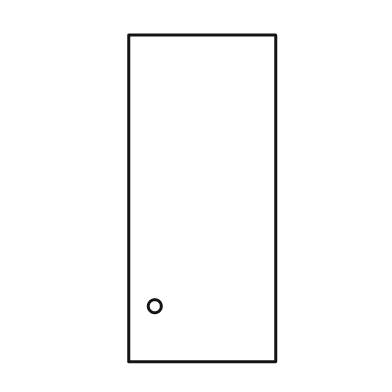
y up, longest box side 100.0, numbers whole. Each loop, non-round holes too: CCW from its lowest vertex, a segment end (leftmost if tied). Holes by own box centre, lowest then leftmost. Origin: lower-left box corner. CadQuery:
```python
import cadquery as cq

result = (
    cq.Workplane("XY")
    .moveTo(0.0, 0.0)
    .lineTo(45.0, 0.0)
    .lineTo(45.0, 100.0)
    .lineTo(0.0, 100.0)
    .close()
    .moveTo(8.0, 17.0)
    .circle(2.0)
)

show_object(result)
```